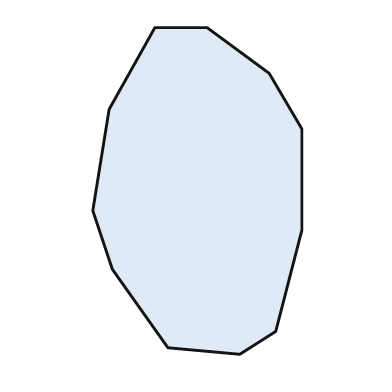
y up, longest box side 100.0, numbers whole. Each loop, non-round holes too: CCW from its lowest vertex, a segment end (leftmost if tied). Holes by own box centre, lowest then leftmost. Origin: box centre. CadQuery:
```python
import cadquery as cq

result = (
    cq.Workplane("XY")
    .moveTo(13.0, -50.0)
    .lineTo(24.0, -43.0)
    .lineTo(32.0, -12.0)
    .lineTo(32.0, 19.0)
    .lineTo(22.0, 36.0)
    .lineTo(3.0, 50.0)
    .lineTo(-13.0, 50.0)
    .lineTo(-27.0, 25.0)
    .lineTo(-32.0, -6.0)
    .lineTo(-26.0, -24.0)
    .lineTo(-9.0, -48.0)
    .close()
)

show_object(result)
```